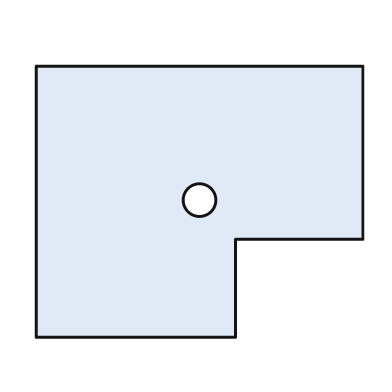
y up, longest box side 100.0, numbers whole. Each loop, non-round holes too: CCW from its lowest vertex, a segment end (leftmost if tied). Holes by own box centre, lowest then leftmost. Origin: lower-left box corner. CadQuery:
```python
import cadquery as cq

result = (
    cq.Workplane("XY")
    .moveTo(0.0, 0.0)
    .lineTo(61.0, 0.0)
    .lineTo(61.0, 30.0)
    .lineTo(100.0, 30.0)
    .lineTo(100.0, 83.0)
    .lineTo(0.0, 83.0)
    .close()
    .moveTo(50.0, 42.0)
    .circle(5.0)
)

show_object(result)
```